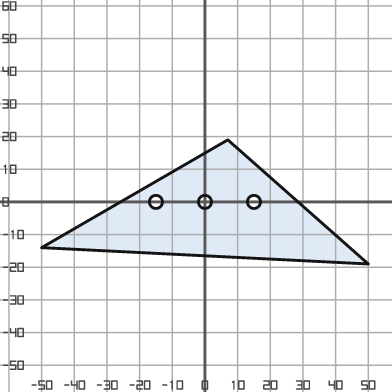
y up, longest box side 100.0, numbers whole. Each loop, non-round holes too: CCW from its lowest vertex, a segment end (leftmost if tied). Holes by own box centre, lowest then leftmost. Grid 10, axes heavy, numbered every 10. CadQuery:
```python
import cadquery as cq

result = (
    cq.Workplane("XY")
    .moveTo(50.0, -19.0)
    .lineTo(7.0, 19.0)
    .lineTo(-50.0, -14.0)
    .close()
    .moveTo(-15.0, 0.0)
    .circle(2.0)
    .moveTo(0.0, 0.0)
    .circle(2.0)
    .moveTo(15.0, 0.0)
    .circle(2.0)
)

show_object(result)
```